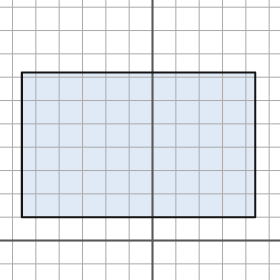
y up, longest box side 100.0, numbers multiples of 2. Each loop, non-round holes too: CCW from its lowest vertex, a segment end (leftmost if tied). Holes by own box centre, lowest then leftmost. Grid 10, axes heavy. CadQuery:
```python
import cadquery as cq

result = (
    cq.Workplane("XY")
    .moveTo(-56.0, 10.0)
    .lineTo(44.0, 10.0)
    .lineTo(44.0, 72.0)
    .lineTo(-56.0, 72.0)
    .close()
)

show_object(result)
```